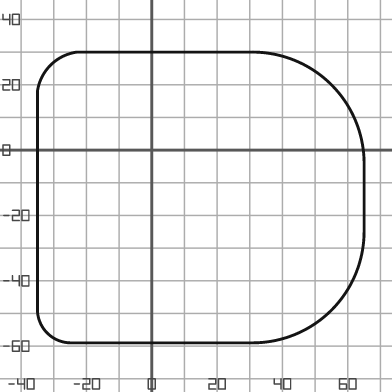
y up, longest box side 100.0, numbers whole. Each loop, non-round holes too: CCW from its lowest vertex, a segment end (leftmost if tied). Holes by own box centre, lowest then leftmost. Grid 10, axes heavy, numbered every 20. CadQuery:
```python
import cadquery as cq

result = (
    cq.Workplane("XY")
    .moveTo(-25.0, -59.0)
    .lineTo(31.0, -59.0)
    .threePointArc((55.0, -49.0), (65.0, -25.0))
    .lineTo(65.0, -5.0)
    .threePointArc((55.0, 20.0), (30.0, 30.0))
    .lineTo(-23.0, 30.0)
    .threePointArc((-31.0, 26.0), (-35.0, 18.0))
    .lineTo(-35.0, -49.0)
    .threePointArc((-32.0, -56.0), (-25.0, -59.0))
    .close()
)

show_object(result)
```